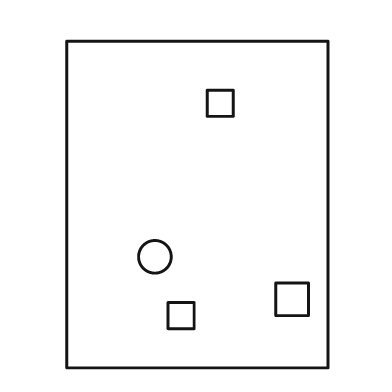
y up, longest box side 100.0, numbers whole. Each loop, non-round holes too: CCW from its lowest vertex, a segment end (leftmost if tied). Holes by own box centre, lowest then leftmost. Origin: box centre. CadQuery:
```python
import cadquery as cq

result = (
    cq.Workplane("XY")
    .moveTo(-40.0, -50.0)
    .lineTo(40.0, -50.0)
    .lineTo(40.0, 50.0)
    .lineTo(-40.0, 50.0)
    .close()
    .moveTo(-9.0, -38.0)
    .lineTo(-1.0, -38.0)
    .lineTo(-1.0, -30.0)
    .lineTo(-9.0, -30.0)
    .close()
    .moveTo(24.0, -34.0)
    .lineTo(34.0, -34.0)
    .lineTo(34.0, -24.0)
    .lineTo(24.0, -24.0)
    .close()
    .moveTo(-13.0, -16.0)
    .circle(5.0)
    .moveTo(3.0, 27.0)
    .lineTo(11.0, 27.0)
    .lineTo(11.0, 35.0)
    .lineTo(3.0, 35.0)
    .close()
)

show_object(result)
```